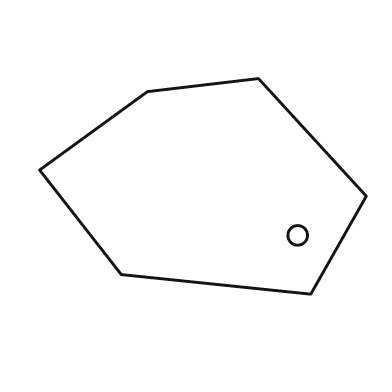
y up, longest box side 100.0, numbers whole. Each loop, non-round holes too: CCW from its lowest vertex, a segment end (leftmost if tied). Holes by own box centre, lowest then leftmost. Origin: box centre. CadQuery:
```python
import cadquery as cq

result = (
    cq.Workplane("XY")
    .moveTo(33.0, -33.0)
    .lineTo(50.0, -3.0)
    .lineTo(17.0, 33.0)
    .lineTo(-17.0, 29.0)
    .lineTo(-50.0, 5.0)
    .lineTo(-25.0, -27.0)
    .close()
    .moveTo(29.0, -15.0)
    .circle(3.0)
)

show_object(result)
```